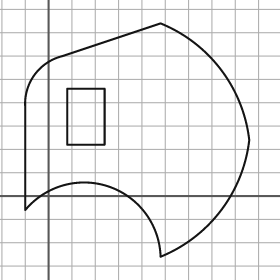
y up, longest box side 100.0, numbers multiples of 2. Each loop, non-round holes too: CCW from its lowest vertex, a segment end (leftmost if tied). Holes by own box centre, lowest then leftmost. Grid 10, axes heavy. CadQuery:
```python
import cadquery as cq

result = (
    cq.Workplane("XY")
    .moveTo(48.0, -26.0)
    .threePointArc((74.0, -6.0), (86.0, 24.0))
    .threePointArc((74.0, 54.0), (48.0, 74.0))
    .lineTo(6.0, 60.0)
    .threePointArc((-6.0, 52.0), (-10.0, 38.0))
    .lineTo(-10.0, -6.0)
    .threePointArc((26.0, 4.0), (48.0, -26.0))
    .close()
    .moveTo(8.0, 22.0)
    .lineTo(24.0, 22.0)
    .lineTo(24.0, 46.0)
    .lineTo(8.0, 46.0)
    .close()
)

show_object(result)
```